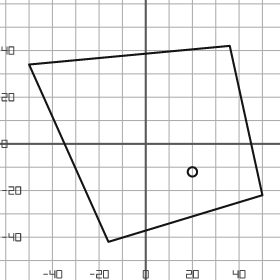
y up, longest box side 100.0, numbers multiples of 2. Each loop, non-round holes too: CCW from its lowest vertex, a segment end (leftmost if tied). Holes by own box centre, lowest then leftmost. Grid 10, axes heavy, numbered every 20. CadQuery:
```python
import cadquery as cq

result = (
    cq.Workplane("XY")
    .moveTo(-16.0, -42.0)
    .lineTo(50.0, -22.0)
    .lineTo(36.0, 42.0)
    .lineTo(-50.0, 34.0)
    .close()
    .moveTo(20.0, -12.0)
    .circle(2.0)
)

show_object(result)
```